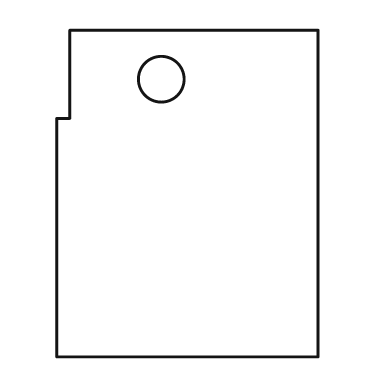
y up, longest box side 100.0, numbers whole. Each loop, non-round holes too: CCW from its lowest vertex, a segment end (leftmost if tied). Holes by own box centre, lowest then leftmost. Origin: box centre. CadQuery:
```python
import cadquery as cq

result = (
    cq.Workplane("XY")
    .moveTo(-40.0, -50.0)
    .lineTo(40.0, -50.0)
    .lineTo(40.0, 50.0)
    .lineTo(-36.0, 50.0)
    .lineTo(-36.0, 23.0)
    .lineTo(-40.0, 23.0)
    .close()
    .moveTo(-8.0, 35.0)
    .circle(7.0)
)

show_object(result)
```